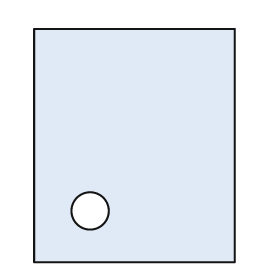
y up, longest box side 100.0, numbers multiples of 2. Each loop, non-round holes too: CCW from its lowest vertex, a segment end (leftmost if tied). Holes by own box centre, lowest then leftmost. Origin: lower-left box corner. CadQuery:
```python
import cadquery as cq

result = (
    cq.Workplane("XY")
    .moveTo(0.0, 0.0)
    .lineTo(86.0, 0.0)
    .lineTo(86.0, 100.0)
    .lineTo(0.0, 100.0)
    .close()
    .moveTo(24.0, 22.0)
    .circle(8.0)
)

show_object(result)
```